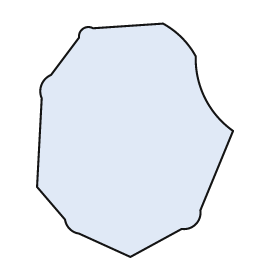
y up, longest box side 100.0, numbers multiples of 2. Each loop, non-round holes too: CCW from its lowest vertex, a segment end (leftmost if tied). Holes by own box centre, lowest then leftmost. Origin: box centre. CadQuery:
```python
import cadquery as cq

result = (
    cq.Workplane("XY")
    .moveTo(-2.0, -50.0)
    .lineTo(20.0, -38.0)
    .threePointArc((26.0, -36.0), (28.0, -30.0))
    .lineTo(42.0, 4.0)
    .threePointArc((30.0, 18.0), (26.0, 36.0))
    .threePointArc((20.0, 44.0), (12.0, 50.0))
    .lineTo(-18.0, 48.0)
    .threePointArc((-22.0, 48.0), (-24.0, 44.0))
    .lineTo(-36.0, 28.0)
    .threePointArc((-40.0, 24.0), (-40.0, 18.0))
    .lineTo(-42.0, -20.0)
    .lineTo(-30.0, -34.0)
    .threePointArc((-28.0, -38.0), (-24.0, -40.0))
    .close()
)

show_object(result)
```